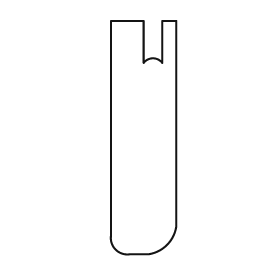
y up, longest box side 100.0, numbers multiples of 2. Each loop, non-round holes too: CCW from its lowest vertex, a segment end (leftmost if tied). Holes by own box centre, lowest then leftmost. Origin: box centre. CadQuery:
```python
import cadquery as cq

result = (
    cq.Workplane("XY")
    .moveTo(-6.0, -50.0)
    .lineTo(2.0, -50.0)
    .threePointArc((10.0, -46.0), (14.0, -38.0))
    .lineTo(14.0, 50.0)
    .lineTo(8.0, 50.0)
    .lineTo(8.0, 32.0)
    .threePointArc((4.0, 34.0), (0.0, 32.0))
    .lineTo(0.0, 50.0)
    .lineTo(-14.0, 50.0)
    .lineTo(-14.0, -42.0)
    .threePointArc((-12.0, -48.0), (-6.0, -50.0))
    .close()
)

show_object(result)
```